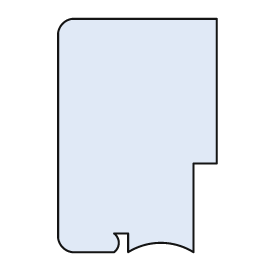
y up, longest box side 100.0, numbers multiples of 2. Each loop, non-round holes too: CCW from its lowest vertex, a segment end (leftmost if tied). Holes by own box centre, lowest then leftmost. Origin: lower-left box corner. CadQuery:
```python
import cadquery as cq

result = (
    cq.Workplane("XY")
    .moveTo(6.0, 0.0)
    .lineTo(24.0, 0.0)
    .threePointArc((26.0, 4.0), (24.0, 8.0))
    .lineTo(30.0, 8.0)
    .lineTo(30.0, 0.0)
    .threePointArc((44.0, 4.0), (58.0, 0.0))
    .lineTo(58.0, 38.0)
    .lineTo(68.0, 38.0)
    .lineTo(68.0, 100.0)
    .lineTo(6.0, 100.0)
    .threePointArc((2.0, 98.0), (0.0, 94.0))
    .lineTo(0.0, 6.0)
    .threePointArc((2.0, 2.0), (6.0, 0.0))
    .close()
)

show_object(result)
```